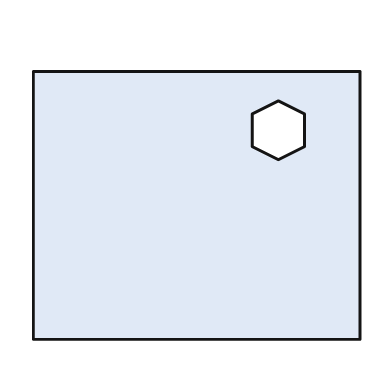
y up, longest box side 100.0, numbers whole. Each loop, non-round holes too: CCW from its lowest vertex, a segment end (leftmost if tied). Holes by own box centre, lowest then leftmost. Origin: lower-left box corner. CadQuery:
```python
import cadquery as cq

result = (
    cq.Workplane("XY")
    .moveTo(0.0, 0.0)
    .lineTo(100.0, 0.0)
    .lineTo(100.0, 82.0)
    .lineTo(0.0, 82.0)
    .close()
    .moveTo(75.0, 55.0)
    .lineTo(83.0, 59.0)
    .lineTo(83.0, 69.0)
    .lineTo(75.0, 73.0)
    .lineTo(67.0, 69.0)
    .lineTo(67.0, 59.0)
    .close()
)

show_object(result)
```